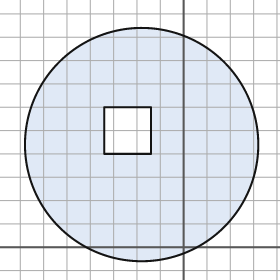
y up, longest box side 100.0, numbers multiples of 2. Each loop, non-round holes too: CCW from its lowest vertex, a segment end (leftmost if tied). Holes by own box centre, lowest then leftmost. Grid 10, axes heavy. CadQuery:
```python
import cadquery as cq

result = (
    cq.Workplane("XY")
    .moveTo(-18.0, 44.0)
    .circle(50.0)
    .moveTo(-34.0, 40.0)
    .lineTo(-14.0, 40.0)
    .lineTo(-14.0, 60.0)
    .lineTo(-34.0, 60.0)
    .close()
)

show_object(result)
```